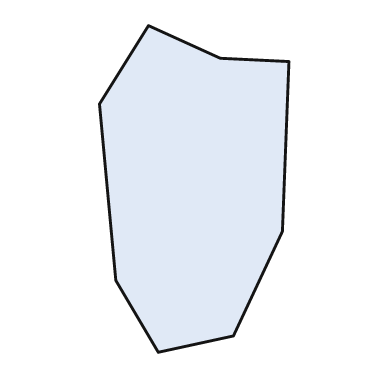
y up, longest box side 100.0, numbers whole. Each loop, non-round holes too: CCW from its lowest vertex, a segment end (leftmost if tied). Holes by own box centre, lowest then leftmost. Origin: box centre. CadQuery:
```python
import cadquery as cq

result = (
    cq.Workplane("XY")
    .moveTo(-11.0, -50.0)
    .lineTo(12.0, -45.0)
    .lineTo(27.0, -13.0)
    .lineTo(29.0, 39.0)
    .lineTo(8.0, 40.0)
    .lineTo(-14.0, 50.0)
    .lineTo(-29.0, 26.0)
    .lineTo(-24.0, -28.0)
    .close()
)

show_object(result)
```